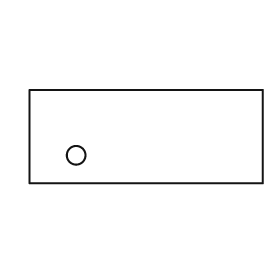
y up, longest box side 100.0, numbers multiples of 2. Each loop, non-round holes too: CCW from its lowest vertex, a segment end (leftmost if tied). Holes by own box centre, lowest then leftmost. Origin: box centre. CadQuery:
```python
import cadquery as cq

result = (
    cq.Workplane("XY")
    .moveTo(-50.0, -20.0)
    .lineTo(50.0, -20.0)
    .lineTo(50.0, 20.0)
    .lineTo(-50.0, 20.0)
    .close()
    .moveTo(-30.0, -8.0)
    .circle(4.0)
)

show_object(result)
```